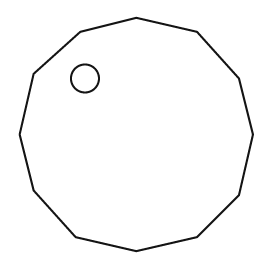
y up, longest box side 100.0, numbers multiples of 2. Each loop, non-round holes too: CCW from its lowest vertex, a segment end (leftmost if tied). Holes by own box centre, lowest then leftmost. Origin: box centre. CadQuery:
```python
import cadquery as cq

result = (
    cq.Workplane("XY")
    .moveTo(0.0, -50.0)
    .lineTo(26.0, -44.0)
    .lineTo(44.0, -26.0)
    .lineTo(50.0, 0.0)
    .lineTo(44.0, 24.0)
    .lineTo(26.0, 44.0)
    .lineTo(0.0, 50.0)
    .lineTo(-24.0, 44.0)
    .lineTo(-44.0, 26.0)
    .lineTo(-50.0, 0.0)
    .lineTo(-44.0, -24.0)
    .lineTo(-26.0, -44.0)
    .close()
    .moveTo(-22.0, 24.0)
    .circle(6.0)
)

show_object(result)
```